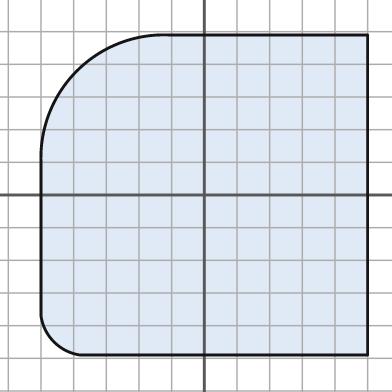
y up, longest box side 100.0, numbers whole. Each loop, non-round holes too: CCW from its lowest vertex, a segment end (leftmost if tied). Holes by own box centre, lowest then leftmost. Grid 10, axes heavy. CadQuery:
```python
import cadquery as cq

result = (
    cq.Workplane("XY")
    .moveTo(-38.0, -49.0)
    .lineTo(50.0, -49.0)
    .lineTo(50.0, 49.0)
    .lineTo(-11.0, 49.0)
    .threePointArc((-39.0, 38.0), (-50.0, 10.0))
    .lineTo(-50.0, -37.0)
    .threePointArc((-46.0, -45.0), (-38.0, -49.0))
    .close()
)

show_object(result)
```